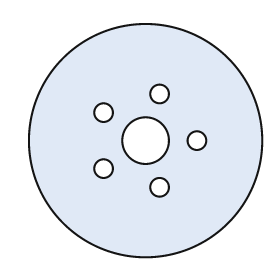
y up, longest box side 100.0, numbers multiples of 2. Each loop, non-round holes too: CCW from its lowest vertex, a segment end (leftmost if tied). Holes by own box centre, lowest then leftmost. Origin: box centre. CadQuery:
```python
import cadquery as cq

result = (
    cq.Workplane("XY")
    .moveTo(0.0, 0.0)
    .circle(50.0)
    .moveTo(6.0, -20.0)
    .circle(4.0)
    .moveTo(-18.0, -12.0)
    .circle(4.0)
    .moveTo(0.0, 0.0)
    .circle(10.0)
    .moveTo(22.0, 0.0)
    .circle(4.0)
    .moveTo(-18.0, 12.0)
    .circle(4.0)
    .moveTo(6.0, 20.0)
    .circle(4.0)
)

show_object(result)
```